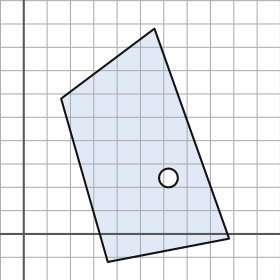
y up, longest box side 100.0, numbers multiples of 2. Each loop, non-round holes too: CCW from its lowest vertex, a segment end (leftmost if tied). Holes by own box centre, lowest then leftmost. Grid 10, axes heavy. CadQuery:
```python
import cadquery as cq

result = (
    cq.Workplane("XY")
    .moveTo(36.0, -12.0)
    .lineTo(88.0, -2.0)
    .lineTo(56.0, 88.0)
    .lineTo(16.0, 58.0)
    .close()
    .moveTo(62.0, 24.0)
    .circle(4.0)
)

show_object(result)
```